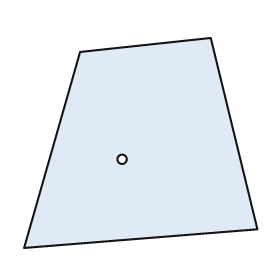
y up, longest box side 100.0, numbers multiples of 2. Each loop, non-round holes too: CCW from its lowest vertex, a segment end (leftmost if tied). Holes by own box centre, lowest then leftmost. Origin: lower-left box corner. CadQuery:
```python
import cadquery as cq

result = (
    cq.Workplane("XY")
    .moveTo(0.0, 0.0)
    .lineTo(100.0, 8.0)
    .lineTo(80.0, 90.0)
    .lineTo(24.0, 84.0)
    .close()
    .moveTo(42.0, 38.0)
    .circle(2.0)
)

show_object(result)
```